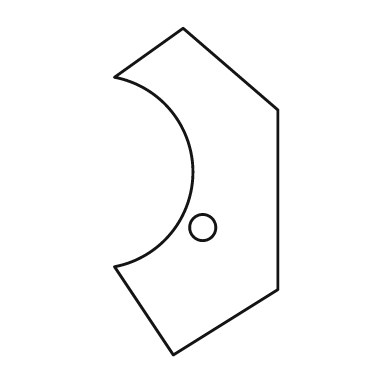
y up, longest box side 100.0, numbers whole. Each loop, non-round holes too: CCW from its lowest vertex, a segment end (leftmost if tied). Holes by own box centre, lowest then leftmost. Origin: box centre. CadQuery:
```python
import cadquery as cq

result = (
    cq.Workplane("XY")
    .moveTo(-7.0, -50.0)
    .lineTo(25.0, -30.0)
    .lineTo(25.0, 25.0)
    .lineTo(-4.0, 50.0)
    .lineTo(-25.0, 35.0)
    .threePointArc((-1.0, 6.0), (-25.0, -23.0))
    .close()
    .moveTo(2.0, -11.0)
    .circle(4.0)
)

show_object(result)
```